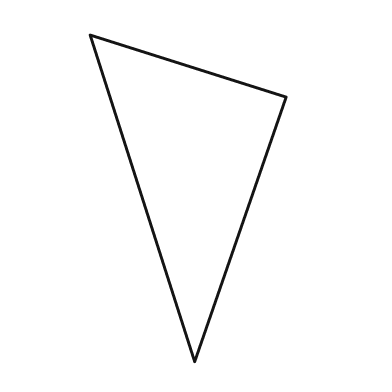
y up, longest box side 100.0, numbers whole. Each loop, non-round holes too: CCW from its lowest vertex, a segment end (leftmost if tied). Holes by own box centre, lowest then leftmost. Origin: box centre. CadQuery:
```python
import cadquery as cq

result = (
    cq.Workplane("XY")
    .moveTo(2.0, -50.0)
    .lineTo(30.0, 31.0)
    .lineTo(-30.0, 50.0)
    .close()
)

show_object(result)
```